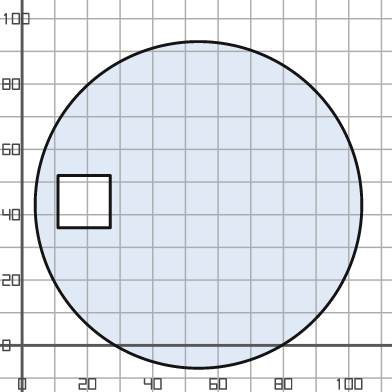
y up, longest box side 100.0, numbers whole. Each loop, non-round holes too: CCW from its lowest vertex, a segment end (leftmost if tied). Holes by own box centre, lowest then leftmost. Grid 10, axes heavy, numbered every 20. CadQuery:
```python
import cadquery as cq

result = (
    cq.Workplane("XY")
    .moveTo(54.0, 43.0)
    .circle(50.0)
    .moveTo(11.0, 36.0)
    .lineTo(27.0, 36.0)
    .lineTo(27.0, 52.0)
    .lineTo(11.0, 52.0)
    .close()
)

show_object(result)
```